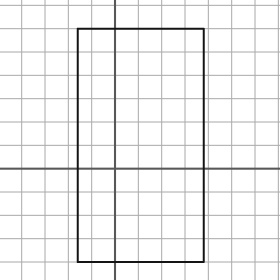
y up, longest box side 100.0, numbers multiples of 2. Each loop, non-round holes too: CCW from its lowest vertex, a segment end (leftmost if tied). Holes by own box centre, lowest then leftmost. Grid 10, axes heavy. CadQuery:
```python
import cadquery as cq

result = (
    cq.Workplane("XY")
    .moveTo(-16.0, -40.0)
    .lineTo(38.0, -40.0)
    .lineTo(38.0, 60.0)
    .lineTo(-16.0, 60.0)
    .close()
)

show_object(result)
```